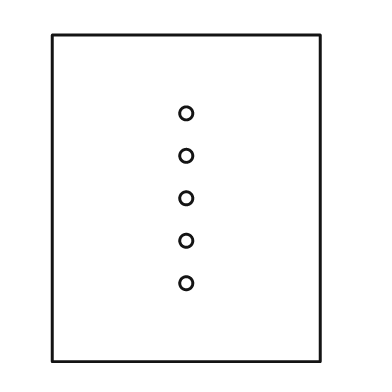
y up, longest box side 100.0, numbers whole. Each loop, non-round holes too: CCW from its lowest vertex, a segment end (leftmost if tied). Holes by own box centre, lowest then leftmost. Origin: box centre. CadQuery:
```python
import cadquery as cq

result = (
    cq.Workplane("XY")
    .moveTo(-41.0, -50.0)
    .lineTo(41.0, -50.0)
    .lineTo(41.0, 50.0)
    .lineTo(-41.0, 50.0)
    .close()
    .moveTo(0.0, -26.0)
    .circle(2.0)
    .moveTo(0.0, -13.0)
    .circle(2.0)
    .moveTo(0.0, 0.0)
    .circle(2.0)
    .moveTo(0.0, 13.0)
    .circle(2.0)
    .moveTo(0.0, 26.0)
    .circle(2.0)
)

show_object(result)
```